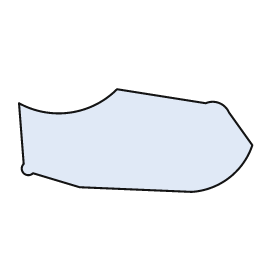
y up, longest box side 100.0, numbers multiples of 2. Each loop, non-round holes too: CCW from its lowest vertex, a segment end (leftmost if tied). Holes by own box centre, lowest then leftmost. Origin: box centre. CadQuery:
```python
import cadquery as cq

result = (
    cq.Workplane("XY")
    .moveTo(24.0, -22.0)
    .threePointArc((40.0, -16.0), (50.0, -2.0))
    .lineTo(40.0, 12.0)
    .threePointArc((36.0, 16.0), (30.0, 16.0))
    .lineTo(-8.0, 22.0)
    .threePointArc((-28.0, 12.0), (-50.0, 16.0))
    .lineTo(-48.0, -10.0)
    .threePointArc((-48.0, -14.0), (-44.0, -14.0))
    .lineTo(-24.0, -20.0)
    .close()
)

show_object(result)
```